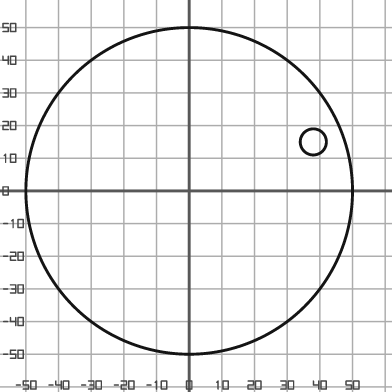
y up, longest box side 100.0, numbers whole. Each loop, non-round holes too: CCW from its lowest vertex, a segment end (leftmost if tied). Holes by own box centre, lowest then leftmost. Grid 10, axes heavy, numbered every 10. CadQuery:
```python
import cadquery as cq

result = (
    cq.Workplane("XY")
    .moveTo(0.0, 0.0)
    .circle(50.0)
    .moveTo(38.0, 15.0)
    .circle(4.0)
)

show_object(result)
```